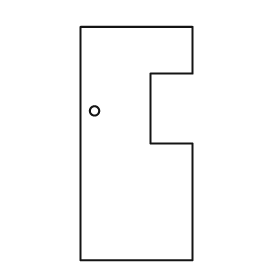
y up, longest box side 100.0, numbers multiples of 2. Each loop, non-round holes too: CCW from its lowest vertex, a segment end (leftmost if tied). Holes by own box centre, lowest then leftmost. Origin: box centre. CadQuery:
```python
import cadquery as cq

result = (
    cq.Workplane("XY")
    .moveTo(-24.0, -50.0)
    .lineTo(24.0, -50.0)
    .lineTo(24.0, 0.0)
    .lineTo(6.0, 0.0)
    .lineTo(6.0, 30.0)
    .lineTo(24.0, 30.0)
    .lineTo(24.0, 50.0)
    .lineTo(-24.0, 50.0)
    .close()
    .moveTo(-18.0, 14.0)
    .circle(2.0)
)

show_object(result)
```